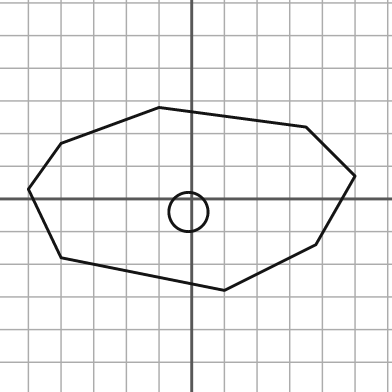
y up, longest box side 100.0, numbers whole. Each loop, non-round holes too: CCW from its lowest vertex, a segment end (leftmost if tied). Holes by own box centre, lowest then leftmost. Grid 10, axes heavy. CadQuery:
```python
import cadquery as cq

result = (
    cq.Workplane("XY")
    .moveTo(10.0, -28.0)
    .lineTo(38.0, -14.0)
    .lineTo(50.0, 7.0)
    .lineTo(35.0, 22.0)
    .lineTo(-10.0, 28.0)
    .lineTo(-40.0, 17.0)
    .lineTo(-50.0, 3.0)
    .lineTo(-40.0, -18.0)
    .close()
    .moveTo(-1.0, -4.0)
    .circle(6.0)
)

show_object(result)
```